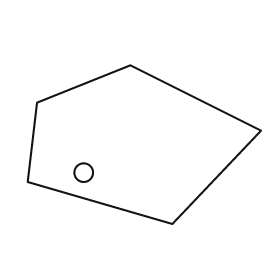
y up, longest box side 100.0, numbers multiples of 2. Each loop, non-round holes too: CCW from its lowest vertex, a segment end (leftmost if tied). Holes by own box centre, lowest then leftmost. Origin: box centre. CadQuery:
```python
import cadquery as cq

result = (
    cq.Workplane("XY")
    .moveTo(12.0, -34.0)
    .lineTo(50.0, 6.0)
    .lineTo(-6.0, 34.0)
    .lineTo(-46.0, 18.0)
    .lineTo(-50.0, -16.0)
    .close()
    .moveTo(-26.0, -12.0)
    .circle(4.0)
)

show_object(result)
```